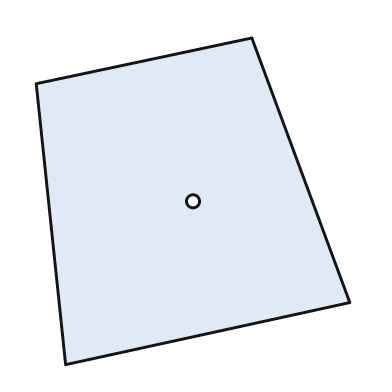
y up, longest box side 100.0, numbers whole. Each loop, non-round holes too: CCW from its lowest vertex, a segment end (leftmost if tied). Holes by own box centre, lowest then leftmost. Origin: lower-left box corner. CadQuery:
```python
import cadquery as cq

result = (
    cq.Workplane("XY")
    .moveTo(9.0, 0.0)
    .lineTo(96.0, 19.0)
    .lineTo(66.0, 100.0)
    .lineTo(0.0, 86.0)
    .close()
    .moveTo(48.0, 50.0)
    .circle(2.0)
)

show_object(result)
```